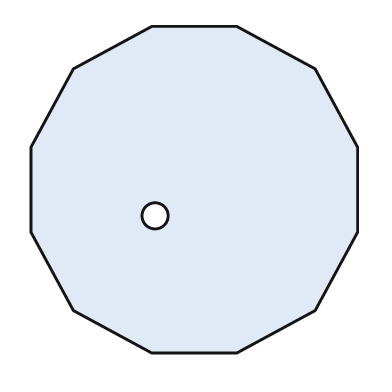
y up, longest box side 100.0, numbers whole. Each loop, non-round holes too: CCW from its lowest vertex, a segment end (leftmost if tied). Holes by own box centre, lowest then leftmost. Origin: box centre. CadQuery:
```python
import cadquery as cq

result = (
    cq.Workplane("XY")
    .moveTo(-13.0, -50.0)
    .lineTo(13.0, -50.0)
    .lineTo(37.0, -37.0)
    .lineTo(50.0, -13.0)
    .lineTo(50.0, 13.0)
    .lineTo(37.0, 37.0)
    .lineTo(13.0, 50.0)
    .lineTo(-13.0, 50.0)
    .lineTo(-37.0, 37.0)
    .lineTo(-50.0, 13.0)
    .lineTo(-50.0, -13.0)
    .lineTo(-37.0, -37.0)
    .close()
    .moveTo(-12.0, -8.0)
    .circle(4.0)
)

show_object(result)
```